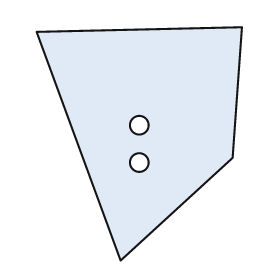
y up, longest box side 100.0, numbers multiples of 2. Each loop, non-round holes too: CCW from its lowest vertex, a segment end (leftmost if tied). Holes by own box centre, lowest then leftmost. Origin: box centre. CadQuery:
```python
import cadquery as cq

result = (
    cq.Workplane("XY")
    .moveTo(-8.0, -50.0)
    .lineTo(40.0, -6.0)
    .lineTo(44.0, 50.0)
    .lineTo(-44.0, 48.0)
    .close()
    .moveTo(0.0, -8.0)
    .circle(4.0)
    .moveTo(0.0, 8.0)
    .circle(4.0)
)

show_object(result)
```